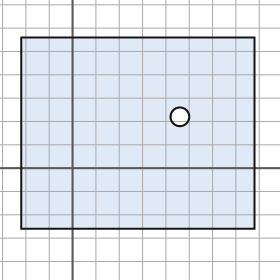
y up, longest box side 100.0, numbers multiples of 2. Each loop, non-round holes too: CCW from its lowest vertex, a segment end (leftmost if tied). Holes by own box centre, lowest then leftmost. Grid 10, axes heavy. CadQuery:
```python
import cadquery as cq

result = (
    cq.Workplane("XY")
    .moveTo(-22.0, -26.0)
    .lineTo(78.0, -26.0)
    .lineTo(78.0, 56.0)
    .lineTo(-22.0, 56.0)
    .close()
    .moveTo(46.0, 22.0)
    .circle(4.0)
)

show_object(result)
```